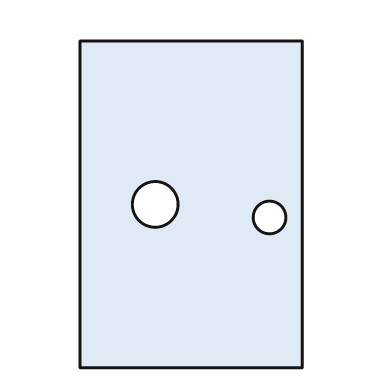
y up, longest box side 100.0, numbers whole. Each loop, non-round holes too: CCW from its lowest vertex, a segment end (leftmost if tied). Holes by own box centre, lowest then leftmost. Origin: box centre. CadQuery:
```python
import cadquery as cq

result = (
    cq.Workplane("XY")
    .moveTo(-34.0, -50.0)
    .lineTo(34.0, -50.0)
    .lineTo(34.0, 50.0)
    .lineTo(-34.0, 50.0)
    .close()
    .moveTo(24.0, -4.0)
    .circle(5.0)
    .moveTo(-11.0, 0.0)
    .circle(7.0)
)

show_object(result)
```